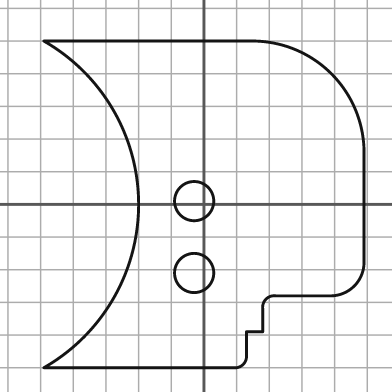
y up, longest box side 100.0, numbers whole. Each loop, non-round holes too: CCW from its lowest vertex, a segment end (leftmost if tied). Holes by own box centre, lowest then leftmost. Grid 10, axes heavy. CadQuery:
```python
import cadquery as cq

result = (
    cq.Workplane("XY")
    .moveTo(-49.0, -50.0)
    .lineTo(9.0, -50.0)
    .threePointArc((12.0, -49.0), (13.0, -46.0))
    .lineTo(13.0, -39.0)
    .lineTo(18.0, -39.0)
    .lineTo(18.0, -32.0)
    .threePointArc((19.0, -29.0), (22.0, -28.0))
    .lineTo(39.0, -28.0)
    .threePointArc((46.0, -25.0), (49.0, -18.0))
    .lineTo(49.0, 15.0)
    .threePointArc((39.0, 40.0), (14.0, 50.0))
    .lineTo(-49.0, 50.0)
    .threePointArc((-20.0, 0.0), (-49.0, -50.0))
    .close()
    .moveTo(-3.0, -21.0)
    .circle(6.0)
    .moveTo(-3.0, 1.0)
    .circle(6.0)
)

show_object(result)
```